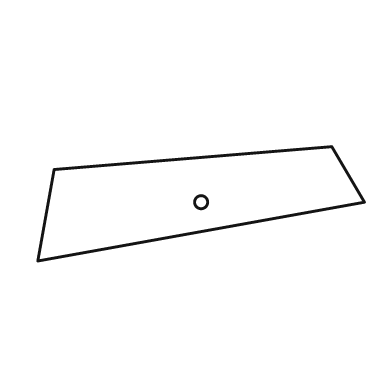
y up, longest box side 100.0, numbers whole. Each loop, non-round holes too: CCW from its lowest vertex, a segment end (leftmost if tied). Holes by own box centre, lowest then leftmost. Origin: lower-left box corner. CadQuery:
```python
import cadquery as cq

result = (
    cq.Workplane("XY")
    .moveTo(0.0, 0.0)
    .lineTo(100.0, 18.0)
    .lineTo(90.0, 35.0)
    .lineTo(5.0, 28.0)
    .close()
    .moveTo(50.0, 18.0)
    .circle(2.0)
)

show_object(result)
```